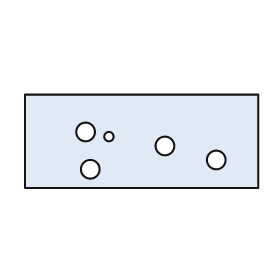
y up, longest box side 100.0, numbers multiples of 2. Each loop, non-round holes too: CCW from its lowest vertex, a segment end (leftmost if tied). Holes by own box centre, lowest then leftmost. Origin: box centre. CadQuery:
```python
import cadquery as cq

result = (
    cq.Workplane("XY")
    .moveTo(-50.0, -20.0)
    .lineTo(50.0, -20.0)
    .lineTo(50.0, 20.0)
    .lineTo(-50.0, 20.0)
    .close()
    .moveTo(-22.0, -12.0)
    .circle(4.0)
    .moveTo(32.0, -8.0)
    .circle(4.0)
    .moveTo(10.0, -2.0)
    .circle(4.0)
    .moveTo(-14.0, 2.0)
    .circle(2.0)
    .moveTo(-24.0, 4.0)
    .circle(4.0)
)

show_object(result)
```